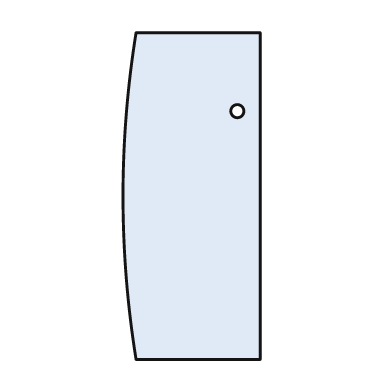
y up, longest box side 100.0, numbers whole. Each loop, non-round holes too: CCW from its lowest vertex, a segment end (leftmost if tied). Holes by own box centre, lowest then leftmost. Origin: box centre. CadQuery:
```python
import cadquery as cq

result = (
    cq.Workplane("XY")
    .moveTo(-17.0, -50.0)
    .lineTo(21.0, -50.0)
    .lineTo(21.0, 50.0)
    .lineTo(-17.0, 50.0)
    .threePointArc((-21.0, 0.0), (-17.0, -50.0))
    .close()
    .moveTo(14.0, 26.0)
    .circle(2.0)
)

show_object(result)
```